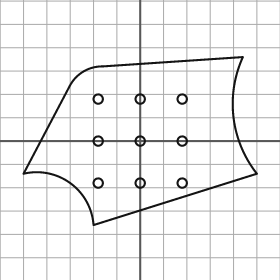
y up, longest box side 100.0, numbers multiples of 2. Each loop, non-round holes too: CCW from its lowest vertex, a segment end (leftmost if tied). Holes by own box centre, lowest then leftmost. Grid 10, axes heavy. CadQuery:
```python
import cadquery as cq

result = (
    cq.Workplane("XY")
    .moveTo(-20.0, -36.0)
    .lineTo(50.0, -14.0)
    .threePointArc((40.0, 10.0), (44.0, 36.0))
    .lineTo(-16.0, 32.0)
    .threePointArc((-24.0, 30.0), (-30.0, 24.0))
    .lineTo(-50.0, -14.0)
    .threePointArc((-30.0, -18.0), (-20.0, -36.0))
    .close()
    .moveTo(-18.0, -18.0)
    .circle(2.0)
    .moveTo(0.0, -18.0)
    .circle(2.0)
    .moveTo(18.0, -18.0)
    .circle(2.0)
    .moveTo(-18.0, 0.0)
    .circle(2.0)
    .moveTo(0.0, 0.0)
    .circle(2.0)
    .moveTo(18.0, 0.0)
    .circle(2.0)
    .moveTo(-18.0, 18.0)
    .circle(2.0)
    .moveTo(0.0, 18.0)
    .circle(2.0)
    .moveTo(18.0, 18.0)
    .circle(2.0)
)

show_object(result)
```